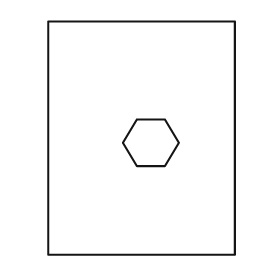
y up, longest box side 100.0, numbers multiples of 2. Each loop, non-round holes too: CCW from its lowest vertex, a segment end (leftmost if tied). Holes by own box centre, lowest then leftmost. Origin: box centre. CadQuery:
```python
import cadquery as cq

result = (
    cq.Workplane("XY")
    .moveTo(-40.0, -50.0)
    .lineTo(40.0, -50.0)
    .lineTo(40.0, 50.0)
    .lineTo(-40.0, 50.0)
    .close()
    .moveTo(-2.0, -12.0)
    .lineTo(10.0, -12.0)
    .lineTo(16.0, -2.0)
    .lineTo(10.0, 8.0)
    .lineTo(-2.0, 8.0)
    .lineTo(-8.0, -2.0)
    .close()
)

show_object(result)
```